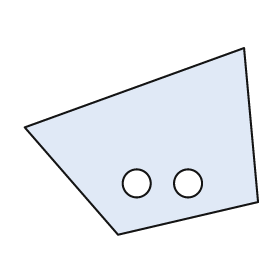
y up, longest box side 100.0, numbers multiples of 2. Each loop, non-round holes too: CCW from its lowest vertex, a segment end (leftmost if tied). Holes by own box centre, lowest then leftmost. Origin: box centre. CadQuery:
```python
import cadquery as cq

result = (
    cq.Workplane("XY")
    .moveTo(-10.0, -40.0)
    .lineTo(50.0, -26.0)
    .lineTo(44.0, 40.0)
    .lineTo(-50.0, 6.0)
    .close()
    .moveTo(-2.0, -18.0)
    .circle(6.0)
    .moveTo(20.0, -18.0)
    .circle(6.0)
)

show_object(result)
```